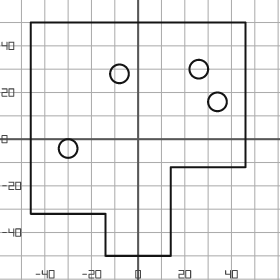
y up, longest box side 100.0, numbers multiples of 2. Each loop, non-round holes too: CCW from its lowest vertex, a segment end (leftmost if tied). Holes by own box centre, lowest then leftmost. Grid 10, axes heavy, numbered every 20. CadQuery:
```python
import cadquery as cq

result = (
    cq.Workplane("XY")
    .moveTo(-14.0, -50.0)
    .lineTo(14.0, -50.0)
    .lineTo(14.0, -12.0)
    .lineTo(46.0, -12.0)
    .lineTo(46.0, 50.0)
    .lineTo(-46.0, 50.0)
    .lineTo(-46.0, -32.0)
    .lineTo(-14.0, -32.0)
    .close()
    .moveTo(-30.0, -4.0)
    .circle(4.0)
    .moveTo(34.0, 16.0)
    .circle(4.0)
    .moveTo(-8.0, 28.0)
    .circle(4.0)
    .moveTo(26.0, 30.0)
    .circle(4.0)
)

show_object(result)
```